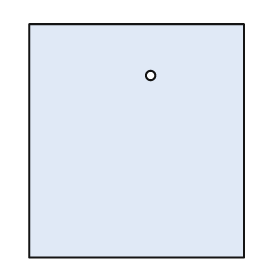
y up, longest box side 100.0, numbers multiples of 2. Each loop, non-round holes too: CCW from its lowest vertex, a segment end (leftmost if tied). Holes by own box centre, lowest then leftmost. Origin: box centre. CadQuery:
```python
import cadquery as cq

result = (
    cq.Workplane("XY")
    .moveTo(-46.0, -50.0)
    .lineTo(46.0, -50.0)
    .lineTo(46.0, 50.0)
    .lineTo(-46.0, 50.0)
    .close()
    .moveTo(6.0, 28.0)
    .circle(2.0)
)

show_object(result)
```